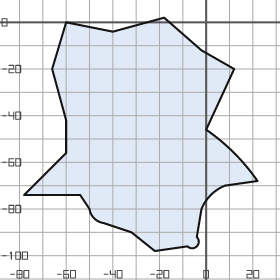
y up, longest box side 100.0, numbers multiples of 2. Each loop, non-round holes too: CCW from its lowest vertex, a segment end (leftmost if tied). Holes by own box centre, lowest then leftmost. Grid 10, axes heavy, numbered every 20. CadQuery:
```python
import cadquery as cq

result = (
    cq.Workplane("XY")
    .moveTo(-22.0, -98.0)
    .lineTo(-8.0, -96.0)
    .threePointArc((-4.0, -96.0), (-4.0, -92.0))
    .lineTo(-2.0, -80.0)
    .threePointArc((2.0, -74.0), (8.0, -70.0))
    .lineTo(22.0, -68.0)
    .threePointArc((12.0, -56.0), (0.0, -46.0))
    .lineTo(12.0, -20.0)
    .lineTo(-2.0, -12.0)
    .lineTo(-18.0, 2.0)
    .lineTo(-40.0, -4.0)
    .lineTo(-60.0, 0.0)
    .lineTo(-66.0, -20.0)
    .lineTo(-60.0, -42.0)
    .lineTo(-60.0, -56.0)
    .lineTo(-78.0, -74.0)
    .lineTo(-54.0, -74.0)
    .lineTo(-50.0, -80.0)
    .threePointArc((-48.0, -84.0), (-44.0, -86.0))
    .lineTo(-32.0, -90.0)
    .close()
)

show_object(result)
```